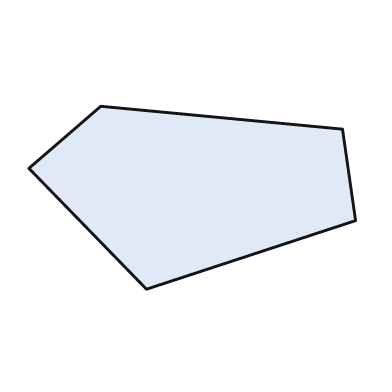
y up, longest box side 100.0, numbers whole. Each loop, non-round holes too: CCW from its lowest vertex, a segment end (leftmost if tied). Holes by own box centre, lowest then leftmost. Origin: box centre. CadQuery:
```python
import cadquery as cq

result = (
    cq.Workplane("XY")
    .moveTo(-14.0, -28.0)
    .lineTo(50.0, -7.0)
    .lineTo(46.0, 21.0)
    .lineTo(-28.0, 28.0)
    .lineTo(-50.0, 9.0)
    .close()
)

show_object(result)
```